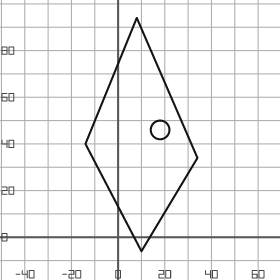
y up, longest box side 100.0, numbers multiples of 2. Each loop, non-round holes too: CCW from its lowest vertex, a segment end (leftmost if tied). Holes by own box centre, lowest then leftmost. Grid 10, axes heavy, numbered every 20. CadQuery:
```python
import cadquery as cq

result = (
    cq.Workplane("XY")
    .moveTo(10.0, -6.0)
    .lineTo(34.0, 34.0)
    .lineTo(8.0, 94.0)
    .lineTo(-14.0, 40.0)
    .close()
    .moveTo(18.0, 46.0)
    .circle(4.0)
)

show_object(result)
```